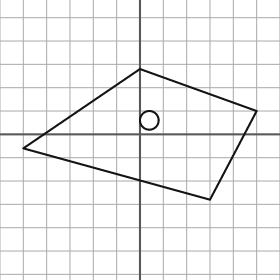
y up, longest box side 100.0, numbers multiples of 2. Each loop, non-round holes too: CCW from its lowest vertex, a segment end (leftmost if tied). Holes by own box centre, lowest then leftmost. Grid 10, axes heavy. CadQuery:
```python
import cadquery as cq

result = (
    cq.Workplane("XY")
    .moveTo(30.0, -28.0)
    .lineTo(50.0, 10.0)
    .lineTo(0.0, 28.0)
    .lineTo(-50.0, -6.0)
    .close()
    .moveTo(4.0, 6.0)
    .circle(4.0)
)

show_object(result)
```